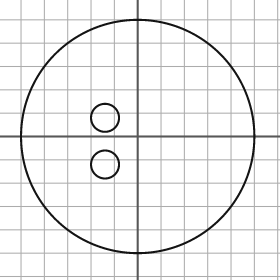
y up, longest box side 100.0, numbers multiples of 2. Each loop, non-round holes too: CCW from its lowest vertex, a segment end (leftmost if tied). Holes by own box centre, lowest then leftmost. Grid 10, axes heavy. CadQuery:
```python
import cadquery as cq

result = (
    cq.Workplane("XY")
    .moveTo(0.0, 0.0)
    .circle(50.0)
    .moveTo(-14.0, -12.0)
    .circle(6.0)
    .moveTo(-14.0, 8.0)
    .circle(6.0)
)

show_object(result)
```